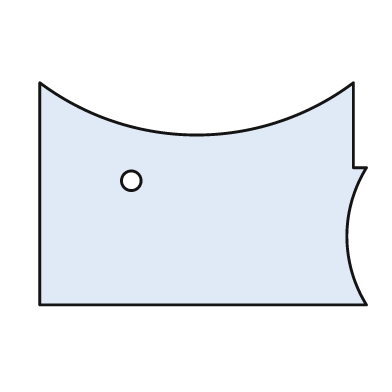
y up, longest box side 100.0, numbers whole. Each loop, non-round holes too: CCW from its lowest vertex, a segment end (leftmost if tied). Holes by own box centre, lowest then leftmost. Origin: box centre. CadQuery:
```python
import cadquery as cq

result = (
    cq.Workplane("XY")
    .moveTo(-50.0, -34.0)
    .lineTo(50.0, -34.0)
    .threePointArc((44.0, -13.0), (50.0, 8.0))
    .lineTo(46.0, 8.0)
    .lineTo(46.0, 34.0)
    .threePointArc((-2.0, 18.0), (-50.0, 34.0))
    .close()
    .moveTo(-22.0, 4.0)
    .circle(3.0)
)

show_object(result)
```